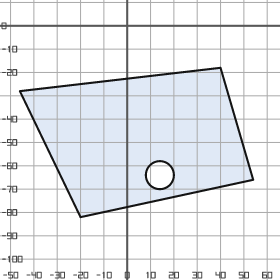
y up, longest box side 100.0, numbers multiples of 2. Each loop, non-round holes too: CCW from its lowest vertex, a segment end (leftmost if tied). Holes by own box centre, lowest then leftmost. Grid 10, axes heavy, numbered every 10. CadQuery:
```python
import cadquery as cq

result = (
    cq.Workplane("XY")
    .moveTo(-20.0, -82.0)
    .lineTo(54.0, -66.0)
    .lineTo(40.0, -18.0)
    .lineTo(-46.0, -28.0)
    .close()
    .moveTo(14.0, -64.0)
    .circle(6.0)
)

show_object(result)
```